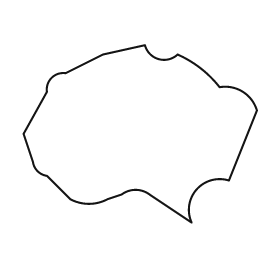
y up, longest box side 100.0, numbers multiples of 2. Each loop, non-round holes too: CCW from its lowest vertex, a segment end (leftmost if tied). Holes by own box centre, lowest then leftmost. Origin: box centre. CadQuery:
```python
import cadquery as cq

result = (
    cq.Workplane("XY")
    .moveTo(22.0, -38.0)
    .threePointArc((24.0, -24.0), (38.0, -20.0))
    .lineTo(50.0, 10.0)
    .threePointArc((44.0, 18.0), (34.0, 20.0))
    .threePointArc((26.0, 28.0), (16.0, 34.0))
    .threePointArc((8.0, 32.0), (2.0, 38.0))
    .lineTo(-16.0, 34.0)
    .lineTo(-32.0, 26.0)
    .threePointArc((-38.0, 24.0), (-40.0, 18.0))
    .lineTo(-50.0, 0.0)
    .lineTo(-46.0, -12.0)
    .threePointArc((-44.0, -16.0), (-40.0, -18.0))
    .lineTo(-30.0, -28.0)
    .threePointArc((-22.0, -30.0), (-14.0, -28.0))
    .lineTo(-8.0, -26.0)
    .threePointArc((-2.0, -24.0), (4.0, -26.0))
    .close()
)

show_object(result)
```